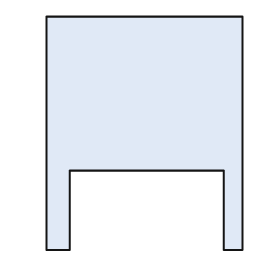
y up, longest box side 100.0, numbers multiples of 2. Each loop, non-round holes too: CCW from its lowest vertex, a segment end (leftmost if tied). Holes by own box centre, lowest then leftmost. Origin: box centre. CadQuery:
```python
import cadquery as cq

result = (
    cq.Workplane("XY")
    .moveTo(-42.0, -50.0)
    .lineTo(-32.0, -50.0)
    .lineTo(-32.0, -16.0)
    .lineTo(34.0, -16.0)
    .lineTo(34.0, -50.0)
    .lineTo(42.0, -50.0)
    .lineTo(42.0, 50.0)
    .lineTo(-42.0, 50.0)
    .close()
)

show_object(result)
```